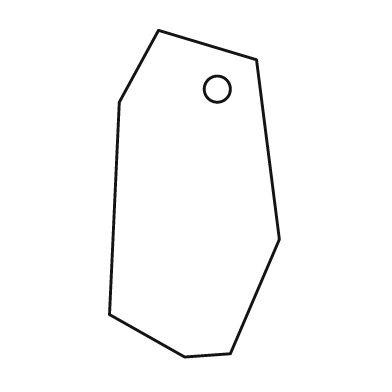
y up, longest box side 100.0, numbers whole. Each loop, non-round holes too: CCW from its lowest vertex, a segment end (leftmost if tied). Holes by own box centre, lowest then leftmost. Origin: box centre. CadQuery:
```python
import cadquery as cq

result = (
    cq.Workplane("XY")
    .moveTo(-3.0, -50.0)
    .lineTo(11.0, -49.0)
    .lineTo(26.0, -14.0)
    .lineTo(19.0, 41.0)
    .lineTo(-11.0, 50.0)
    .lineTo(-23.0, 28.0)
    .lineTo(-26.0, -37.0)
    .close()
    .moveTo(7.0, 32.0)
    .circle(4.0)
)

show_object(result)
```